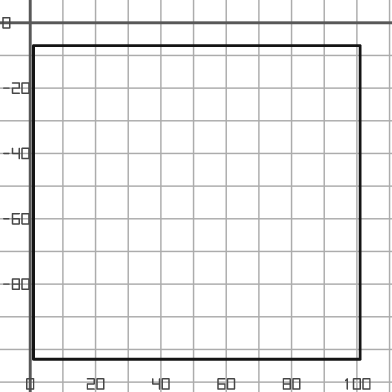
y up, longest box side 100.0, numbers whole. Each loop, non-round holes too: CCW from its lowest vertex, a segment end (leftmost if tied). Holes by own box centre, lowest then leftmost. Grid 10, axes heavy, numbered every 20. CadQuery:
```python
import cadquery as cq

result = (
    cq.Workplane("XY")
    .moveTo(1.0, -103.0)
    .lineTo(101.0, -103.0)
    .lineTo(101.0, -7.0)
    .lineTo(1.0, -7.0)
    .close()
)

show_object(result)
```